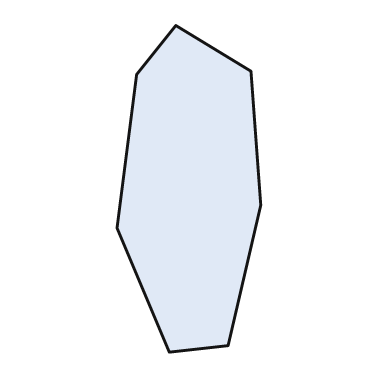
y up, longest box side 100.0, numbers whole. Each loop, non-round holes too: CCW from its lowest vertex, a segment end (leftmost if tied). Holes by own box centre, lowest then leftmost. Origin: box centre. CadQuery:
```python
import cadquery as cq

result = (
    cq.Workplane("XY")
    .moveTo(-6.0, -50.0)
    .lineTo(12.0, -48.0)
    .lineTo(22.0, -5.0)
    .lineTo(19.0, 36.0)
    .lineTo(-4.0, 50.0)
    .lineTo(-16.0, 35.0)
    .lineTo(-22.0, -12.0)
    .close()
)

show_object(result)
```